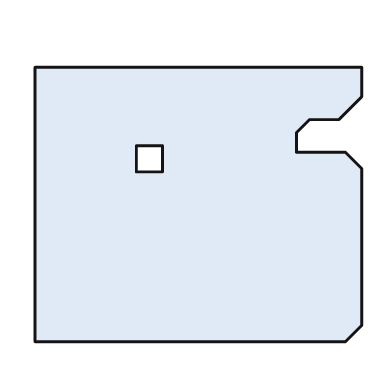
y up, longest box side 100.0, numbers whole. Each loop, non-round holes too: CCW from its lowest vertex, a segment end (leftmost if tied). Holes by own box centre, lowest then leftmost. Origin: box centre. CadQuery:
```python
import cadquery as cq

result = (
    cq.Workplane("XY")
    .moveTo(-50.0, -42.0)
    .lineTo(45.0, -42.0)
    .lineTo(50.0, -37.0)
    .lineTo(50.0, 11.0)
    .lineTo(45.0, 16.0)
    .lineTo(30.0, 16.0)
    .lineTo(30.0, 22.0)
    .lineTo(34.0, 26.0)
    .lineTo(43.0, 26.0)
    .lineTo(50.0, 33.0)
    .lineTo(50.0, 42.0)
    .lineTo(-50.0, 42.0)
    .close()
    .moveTo(-19.0, 10.0)
    .lineTo(-11.0, 10.0)
    .lineTo(-11.0, 18.0)
    .lineTo(-19.0, 18.0)
    .close()
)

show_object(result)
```